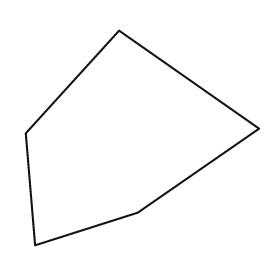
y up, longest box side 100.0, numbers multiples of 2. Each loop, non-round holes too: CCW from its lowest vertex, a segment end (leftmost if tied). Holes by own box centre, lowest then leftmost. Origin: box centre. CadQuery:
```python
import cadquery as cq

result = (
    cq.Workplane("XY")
    .moveTo(-46.0, -46.0)
    .lineTo(-2.0, -32.0)
    .lineTo(50.0, 4.0)
    .lineTo(-10.0, 46.0)
    .lineTo(-50.0, 2.0)
    .close()
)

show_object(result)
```